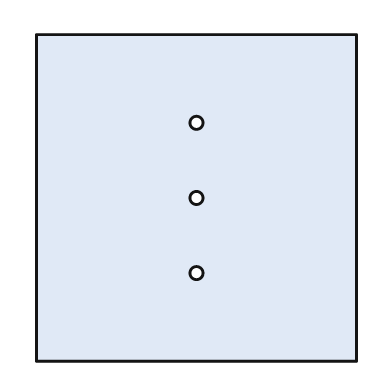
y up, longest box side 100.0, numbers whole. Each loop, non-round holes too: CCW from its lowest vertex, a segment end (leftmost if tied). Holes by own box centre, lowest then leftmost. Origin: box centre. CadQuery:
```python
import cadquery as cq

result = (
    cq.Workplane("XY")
    .moveTo(-49.0, -50.0)
    .lineTo(49.0, -50.0)
    .lineTo(49.0, 50.0)
    .lineTo(-49.0, 50.0)
    .close()
    .moveTo(0.0, -23.0)
    .circle(2.0)
    .moveTo(0.0, 0.0)
    .circle(2.0)
    .moveTo(0.0, 23.0)
    .circle(2.0)
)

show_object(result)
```